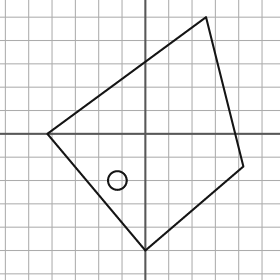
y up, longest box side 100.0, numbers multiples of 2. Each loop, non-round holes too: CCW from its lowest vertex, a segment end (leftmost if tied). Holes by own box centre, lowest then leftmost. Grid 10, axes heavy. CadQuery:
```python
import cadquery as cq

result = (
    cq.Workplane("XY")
    .moveTo(0.0, -50.0)
    .lineTo(42.0, -14.0)
    .lineTo(26.0, 50.0)
    .lineTo(-42.0, 0.0)
    .close()
    .moveTo(-12.0, -20.0)
    .circle(4.0)
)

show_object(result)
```